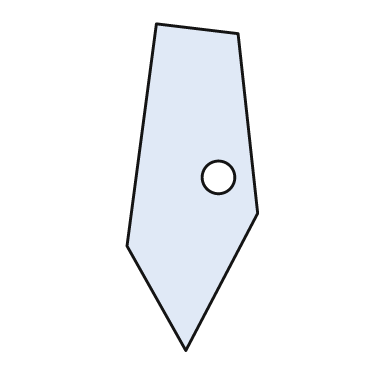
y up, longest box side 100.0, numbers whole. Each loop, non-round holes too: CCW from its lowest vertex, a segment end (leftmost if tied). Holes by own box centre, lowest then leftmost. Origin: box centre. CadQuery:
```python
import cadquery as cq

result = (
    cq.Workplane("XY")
    .moveTo(-2.0, -50.0)
    .lineTo(20.0, -8.0)
    .lineTo(14.0, 47.0)
    .lineTo(-11.0, 50.0)
    .lineTo(-20.0, -18.0)
    .close()
    .moveTo(8.0, 3.0)
    .circle(5.0)
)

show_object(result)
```